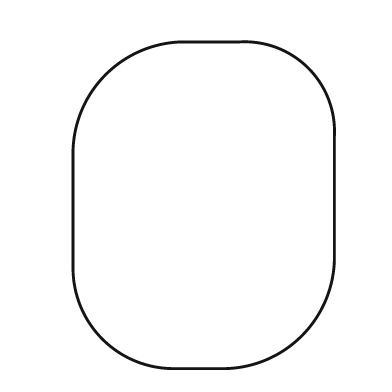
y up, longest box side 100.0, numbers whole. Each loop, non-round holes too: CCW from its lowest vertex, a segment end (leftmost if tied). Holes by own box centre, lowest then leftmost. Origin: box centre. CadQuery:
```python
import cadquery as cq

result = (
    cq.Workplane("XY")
    .moveTo(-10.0, -50.0)
    .lineTo(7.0, -50.0)
    .threePointArc((30.0, -40.0), (40.0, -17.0))
    .lineTo(40.0, 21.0)
    .threePointArc((32.0, 42.0), (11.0, 50.0))
    .lineTo(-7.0, 50.0)
    .threePointArc((-30.0, 40.0), (-40.0, 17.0))
    .lineTo(-40.0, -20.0)
    .threePointArc((-31.0, -41.0), (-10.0, -50.0))
    .close()
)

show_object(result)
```